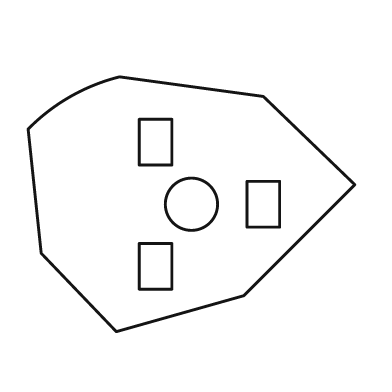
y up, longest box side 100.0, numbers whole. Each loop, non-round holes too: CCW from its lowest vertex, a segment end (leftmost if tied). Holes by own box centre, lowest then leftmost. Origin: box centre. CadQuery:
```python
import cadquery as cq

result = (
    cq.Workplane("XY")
    .moveTo(-23.0, -39.0)
    .lineTo(16.0, -28.0)
    .lineTo(50.0, 6.0)
    .lineTo(22.0, 33.0)
    .lineTo(-22.0, 39.0)
    .threePointArc((-37.0, 33.0), (-50.0, 23.0))
    .lineTo(-46.0, -15.0)
    .close()
    .moveTo(-16.0, -26.0)
    .lineTo(-6.0, -26.0)
    .lineTo(-6.0, -12.0)
    .lineTo(-16.0, -12.0)
    .close()
    .moveTo(0.0, 0.0)
    .circle(8.0)
    .moveTo(17.0, -7.0)
    .lineTo(27.0, -7.0)
    .lineTo(27.0, 7.0)
    .lineTo(17.0, 7.0)
    .close()
    .moveTo(-16.0, 12.0)
    .lineTo(-6.0, 12.0)
    .lineTo(-6.0, 26.0)
    .lineTo(-16.0, 26.0)
    .close()
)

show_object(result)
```